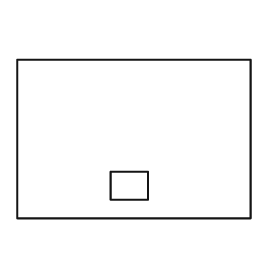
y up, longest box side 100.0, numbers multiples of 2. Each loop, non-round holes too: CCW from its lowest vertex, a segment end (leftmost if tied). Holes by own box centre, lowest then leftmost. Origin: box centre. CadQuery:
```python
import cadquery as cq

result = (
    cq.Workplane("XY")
    .moveTo(-50.0, -34.0)
    .lineTo(50.0, -34.0)
    .lineTo(50.0, 34.0)
    .lineTo(-50.0, 34.0)
    .close()
    .moveTo(-10.0, -26.0)
    .lineTo(6.0, -26.0)
    .lineTo(6.0, -14.0)
    .lineTo(-10.0, -14.0)
    .close()
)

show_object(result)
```